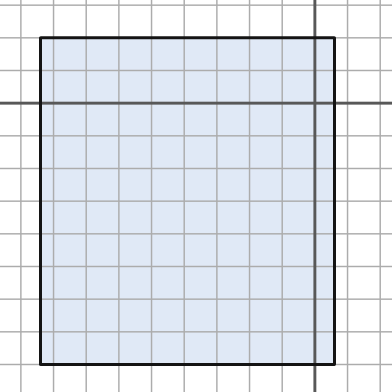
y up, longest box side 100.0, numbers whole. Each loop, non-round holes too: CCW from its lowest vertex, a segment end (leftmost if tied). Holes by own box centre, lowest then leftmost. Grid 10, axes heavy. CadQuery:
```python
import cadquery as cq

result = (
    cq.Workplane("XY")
    .moveTo(-84.0, -80.0)
    .lineTo(6.0, -80.0)
    .lineTo(6.0, 20.0)
    .lineTo(-84.0, 20.0)
    .close()
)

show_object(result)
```